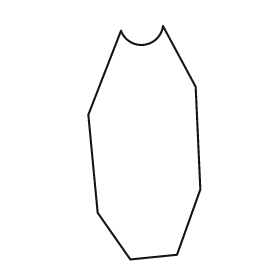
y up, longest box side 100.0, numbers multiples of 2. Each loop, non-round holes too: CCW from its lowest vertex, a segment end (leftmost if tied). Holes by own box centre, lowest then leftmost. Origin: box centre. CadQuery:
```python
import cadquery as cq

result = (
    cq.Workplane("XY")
    .moveTo(-6.0, -50.0)
    .lineTo(14.0, -48.0)
    .lineTo(24.0, -20.0)
    .lineTo(22.0, 24.0)
    .lineTo(8.0, 50.0)
    .threePointArc((0.0, 42.0), (-10.0, 48.0))
    .lineTo(-24.0, 12.0)
    .lineTo(-20.0, -30.0)
    .close()
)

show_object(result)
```